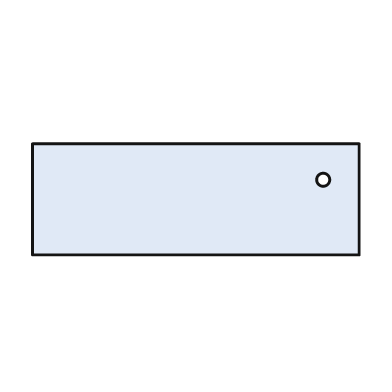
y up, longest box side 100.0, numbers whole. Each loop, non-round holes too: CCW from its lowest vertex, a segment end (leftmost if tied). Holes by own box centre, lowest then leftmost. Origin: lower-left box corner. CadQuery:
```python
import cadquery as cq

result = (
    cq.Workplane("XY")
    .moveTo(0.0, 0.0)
    .lineTo(100.0, 0.0)
    .lineTo(100.0, 34.0)
    .lineTo(0.0, 34.0)
    .close()
    .moveTo(89.0, 23.0)
    .circle(2.0)
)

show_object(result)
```